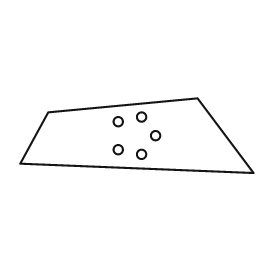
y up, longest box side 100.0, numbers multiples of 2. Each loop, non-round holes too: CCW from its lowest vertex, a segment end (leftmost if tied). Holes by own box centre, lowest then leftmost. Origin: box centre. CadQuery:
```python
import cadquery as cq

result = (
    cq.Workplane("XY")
    .moveTo(50.0, -16.0)
    .lineTo(26.0, 16.0)
    .lineTo(-38.0, 10.0)
    .lineTo(-50.0, -12.0)
    .close()
    .moveTo(2.0, -8.0)
    .circle(2.0)
    .moveTo(-8.0, -6.0)
    .circle(2.0)
    .moveTo(8.0, 0.0)
    .circle(2.0)
    .moveTo(-8.0, 6.0)
    .circle(2.0)
    .moveTo(2.0, 8.0)
    .circle(2.0)
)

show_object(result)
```